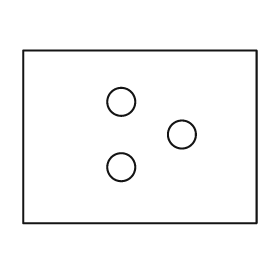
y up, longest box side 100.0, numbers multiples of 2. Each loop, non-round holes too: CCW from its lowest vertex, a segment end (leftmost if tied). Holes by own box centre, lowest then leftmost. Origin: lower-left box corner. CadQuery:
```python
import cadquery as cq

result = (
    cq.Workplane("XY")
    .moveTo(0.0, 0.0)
    .lineTo(100.0, 0.0)
    .lineTo(100.0, 74.0)
    .lineTo(0.0, 74.0)
    .close()
    .moveTo(42.0, 24.0)
    .circle(6.0)
    .moveTo(68.0, 38.0)
    .circle(6.0)
    .moveTo(42.0, 52.0)
    .circle(6.0)
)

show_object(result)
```